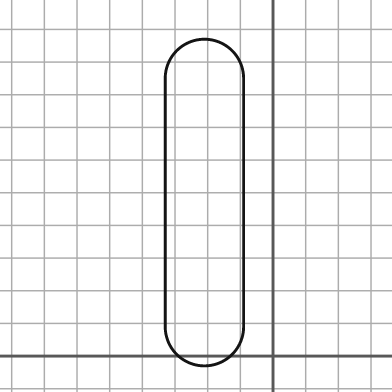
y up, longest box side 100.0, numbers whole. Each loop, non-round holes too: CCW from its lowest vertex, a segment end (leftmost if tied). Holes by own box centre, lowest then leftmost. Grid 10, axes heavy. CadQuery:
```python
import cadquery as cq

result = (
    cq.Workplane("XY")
    .moveTo(-33.0, 9.0)
    .threePointArc((-21.0, -3.0), (-9.0, 9.0))
    .lineTo(-9.0, 85.0)
    .threePointArc((-21.0, 97.0), (-33.0, 85.0))
    .close()
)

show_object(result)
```